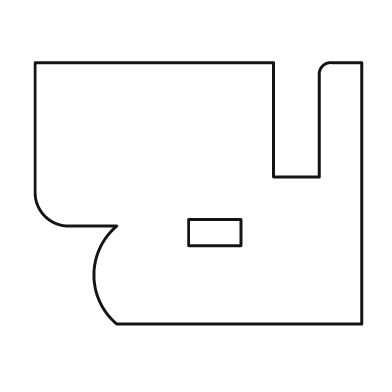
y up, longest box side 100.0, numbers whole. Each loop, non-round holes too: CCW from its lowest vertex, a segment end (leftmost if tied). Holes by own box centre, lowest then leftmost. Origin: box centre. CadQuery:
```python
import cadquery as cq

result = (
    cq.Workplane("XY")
    .moveTo(-25.0, -40.0)
    .lineTo(50.0, -40.0)
    .lineTo(50.0, 40.0)
    .lineTo(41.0, 40.0)
    .threePointArc((38.0, 39.0), (37.0, 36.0))
    .lineTo(37.0, 5.0)
    .lineTo(23.0, 5.0)
    .lineTo(23.0, 40.0)
    .lineTo(-50.0, 40.0)
    .lineTo(-50.0, 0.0)
    .threePointArc((-47.0, -7.0), (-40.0, -10.0))
    .lineTo(-25.0, -10.0)
    .threePointArc((-32.0, -25.0), (-25.0, -40.0))
    .close()
    .moveTo(-3.0, -16.0)
    .lineTo(13.0, -16.0)
    .lineTo(13.0, -8.0)
    .lineTo(-3.0, -8.0)
    .close()
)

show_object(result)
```